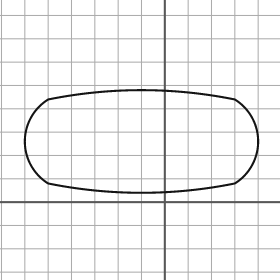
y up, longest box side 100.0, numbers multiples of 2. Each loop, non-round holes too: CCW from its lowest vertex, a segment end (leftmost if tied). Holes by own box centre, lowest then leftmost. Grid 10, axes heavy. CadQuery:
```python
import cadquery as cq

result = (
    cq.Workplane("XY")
    .moveTo(-50.0, 8.0)
    .threePointArc((-10.0, 4.0), (30.0, 8.0))
    .threePointArc((40.0, 26.0), (30.0, 44.0))
    .threePointArc((-10.0, 48.0), (-50.0, 44.0))
    .threePointArc((-60.0, 26.0), (-50.0, 8.0))
    .close()
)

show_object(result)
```